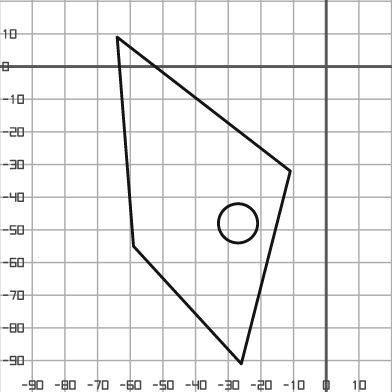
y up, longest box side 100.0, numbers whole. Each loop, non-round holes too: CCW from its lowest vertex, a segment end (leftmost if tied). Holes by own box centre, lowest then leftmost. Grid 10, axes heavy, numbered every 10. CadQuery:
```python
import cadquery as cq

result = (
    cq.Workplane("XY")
    .moveTo(-26.0, -91.0)
    .lineTo(-11.0, -32.0)
    .lineTo(-64.0, 9.0)
    .lineTo(-59.0, -55.0)
    .close()
    .moveTo(-27.0, -48.0)
    .circle(6.0)
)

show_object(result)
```